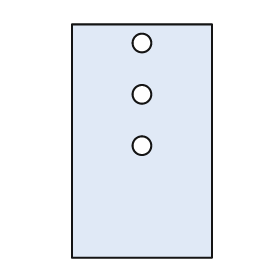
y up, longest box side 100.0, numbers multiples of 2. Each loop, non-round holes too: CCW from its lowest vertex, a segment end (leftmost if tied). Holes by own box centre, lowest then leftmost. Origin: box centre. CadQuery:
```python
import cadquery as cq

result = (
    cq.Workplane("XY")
    .moveTo(-30.0, -50.0)
    .lineTo(30.0, -50.0)
    .lineTo(30.0, 50.0)
    .lineTo(-30.0, 50.0)
    .close()
    .moveTo(0.0, -2.0)
    .circle(4.0)
    .moveTo(0.0, 20.0)
    .circle(4.0)
    .moveTo(0.0, 42.0)
    .circle(4.0)
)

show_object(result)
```